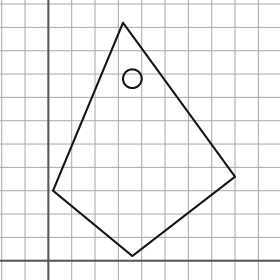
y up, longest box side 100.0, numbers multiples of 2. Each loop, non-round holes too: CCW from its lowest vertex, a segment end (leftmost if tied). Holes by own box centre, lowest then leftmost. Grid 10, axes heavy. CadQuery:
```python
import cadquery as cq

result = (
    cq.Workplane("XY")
    .moveTo(36.0, 2.0)
    .lineTo(80.0, 36.0)
    .lineTo(32.0, 102.0)
    .lineTo(2.0, 30.0)
    .close()
    .moveTo(36.0, 78.0)
    .circle(4.0)
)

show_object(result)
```